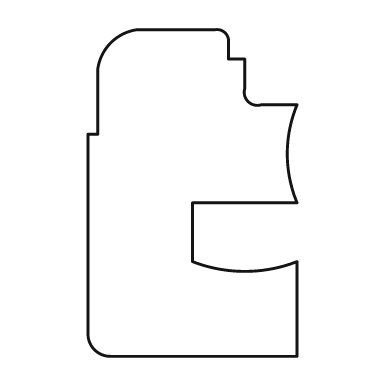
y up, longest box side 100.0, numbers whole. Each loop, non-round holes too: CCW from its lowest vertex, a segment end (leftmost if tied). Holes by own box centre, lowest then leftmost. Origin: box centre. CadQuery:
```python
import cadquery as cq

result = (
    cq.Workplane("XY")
    .moveTo(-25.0, -50.0)
    .lineTo(32.0, -50.0)
    .lineTo(32.0, -21.0)
    .threePointArc((16.0, -24.0), (0.0, -21.0))
    .lineTo(0.0, -3.0)
    .lineTo(32.0, -3.0)
    .threePointArc((29.0, 12.0), (32.0, 27.0))
    .lineTo(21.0, 27.0)
    .threePointArc((17.0, 28.0), (16.0, 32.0))
    .lineTo(16.0, 41.0)
    .lineTo(11.0, 41.0)
    .lineTo(11.0, 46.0)
    .threePointArc((10.0, 49.0), (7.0, 50.0))
    .lineTo(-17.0, 50.0)
    .threePointArc((-25.0, 46.0), (-29.0, 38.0))
    .lineTo(-29.0, 18.0)
    .lineTo(-32.0, 18.0)
    .lineTo(-32.0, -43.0)
    .threePointArc((-30.0, -48.0), (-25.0, -50.0))
    .close()
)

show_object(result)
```